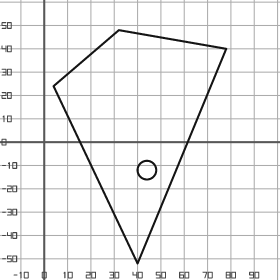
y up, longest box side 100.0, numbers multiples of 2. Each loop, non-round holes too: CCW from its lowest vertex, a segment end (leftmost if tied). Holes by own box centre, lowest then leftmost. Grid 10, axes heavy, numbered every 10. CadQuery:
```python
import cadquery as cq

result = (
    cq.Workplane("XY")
    .moveTo(40.0, -52.0)
    .lineTo(78.0, 40.0)
    .lineTo(32.0, 48.0)
    .lineTo(4.0, 24.0)
    .close()
    .moveTo(44.0, -12.0)
    .circle(4.0)
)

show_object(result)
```